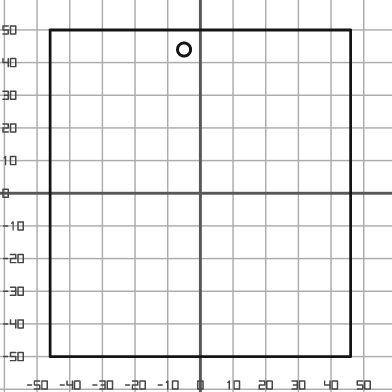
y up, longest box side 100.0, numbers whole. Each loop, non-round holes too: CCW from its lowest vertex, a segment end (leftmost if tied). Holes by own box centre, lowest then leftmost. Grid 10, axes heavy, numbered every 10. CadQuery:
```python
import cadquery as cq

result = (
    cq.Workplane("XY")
    .moveTo(-46.0, -50.0)
    .lineTo(46.0, -50.0)
    .lineTo(46.0, 50.0)
    .lineTo(-46.0, 50.0)
    .close()
    .moveTo(-5.0, 44.0)
    .circle(2.0)
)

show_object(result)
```